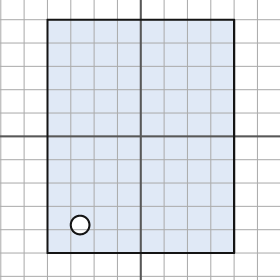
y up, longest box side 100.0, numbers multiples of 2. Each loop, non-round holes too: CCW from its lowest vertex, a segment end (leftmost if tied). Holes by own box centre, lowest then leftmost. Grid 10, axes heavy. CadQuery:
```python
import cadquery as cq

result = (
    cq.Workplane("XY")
    .moveTo(-40.0, -50.0)
    .lineTo(40.0, -50.0)
    .lineTo(40.0, 50.0)
    .lineTo(-40.0, 50.0)
    .close()
    .moveTo(-26.0, -38.0)
    .circle(4.0)
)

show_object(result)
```